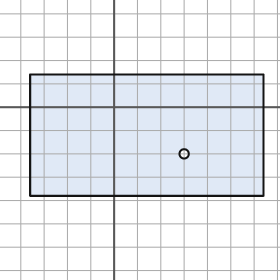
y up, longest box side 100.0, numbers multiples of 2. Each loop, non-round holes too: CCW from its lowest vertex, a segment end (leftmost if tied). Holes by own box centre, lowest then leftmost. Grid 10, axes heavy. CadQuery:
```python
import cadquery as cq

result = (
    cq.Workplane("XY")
    .moveTo(-36.0, -38.0)
    .lineTo(64.0, -38.0)
    .lineTo(64.0, 14.0)
    .lineTo(-36.0, 14.0)
    .close()
    .moveTo(30.0, -20.0)
    .circle(2.0)
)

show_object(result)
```